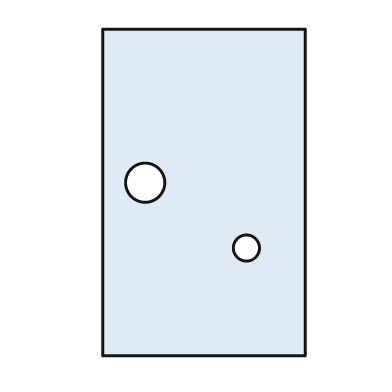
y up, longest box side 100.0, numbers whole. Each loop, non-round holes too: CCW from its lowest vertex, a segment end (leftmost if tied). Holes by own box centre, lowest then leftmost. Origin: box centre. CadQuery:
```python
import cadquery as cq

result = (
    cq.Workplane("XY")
    .moveTo(-31.0, -50.0)
    .lineTo(31.0, -50.0)
    .lineTo(31.0, 50.0)
    .lineTo(-31.0, 50.0)
    .close()
    .moveTo(13.0, -17.0)
    .circle(4.0)
    .moveTo(-18.0, 3.0)
    .circle(6.0)
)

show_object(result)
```